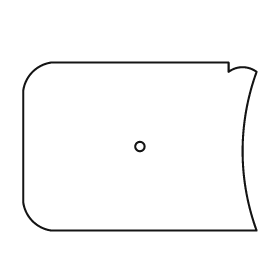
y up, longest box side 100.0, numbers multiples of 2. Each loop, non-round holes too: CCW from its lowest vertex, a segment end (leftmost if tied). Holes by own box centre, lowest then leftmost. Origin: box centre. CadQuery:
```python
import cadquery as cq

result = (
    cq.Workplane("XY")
    .moveTo(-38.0, -36.0)
    .lineTo(50.0, -36.0)
    .threePointArc((44.0, -2.0), (50.0, 32.0))
    .threePointArc((44.0, 34.0), (38.0, 32.0))
    .lineTo(38.0, 36.0)
    .lineTo(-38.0, 36.0)
    .threePointArc((-46.0, 32.0), (-50.0, 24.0))
    .lineTo(-50.0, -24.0)
    .threePointArc((-46.0, -32.0), (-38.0, -36.0))
    .close()
    .moveTo(0.0, 0.0)
    .circle(2.0)
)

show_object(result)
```